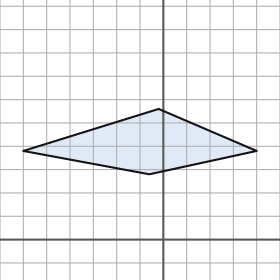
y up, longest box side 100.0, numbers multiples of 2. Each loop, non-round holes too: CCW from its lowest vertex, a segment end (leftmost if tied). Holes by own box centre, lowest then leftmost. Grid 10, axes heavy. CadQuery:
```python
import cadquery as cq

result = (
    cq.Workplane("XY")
    .moveTo(-6.0, 28.0)
    .lineTo(40.0, 38.0)
    .lineTo(-2.0, 56.0)
    .lineTo(-60.0, 38.0)
    .close()
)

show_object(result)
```